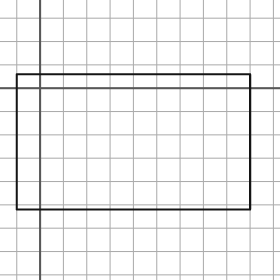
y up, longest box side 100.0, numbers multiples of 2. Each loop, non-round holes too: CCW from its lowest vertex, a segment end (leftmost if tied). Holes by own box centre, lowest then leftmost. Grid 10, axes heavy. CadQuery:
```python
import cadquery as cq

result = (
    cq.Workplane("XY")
    .moveTo(-10.0, -52.0)
    .lineTo(90.0, -52.0)
    .lineTo(90.0, 6.0)
    .lineTo(-10.0, 6.0)
    .close()
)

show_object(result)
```